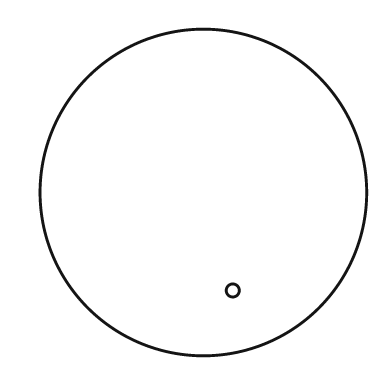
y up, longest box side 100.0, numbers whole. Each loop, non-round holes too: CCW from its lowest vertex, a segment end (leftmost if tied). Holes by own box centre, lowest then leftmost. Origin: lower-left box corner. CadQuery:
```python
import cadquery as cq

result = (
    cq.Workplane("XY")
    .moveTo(50.0, 50.0)
    .circle(50.0)
    .moveTo(59.0, 20.0)
    .circle(2.0)
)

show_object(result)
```